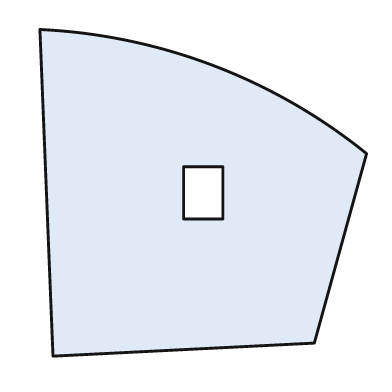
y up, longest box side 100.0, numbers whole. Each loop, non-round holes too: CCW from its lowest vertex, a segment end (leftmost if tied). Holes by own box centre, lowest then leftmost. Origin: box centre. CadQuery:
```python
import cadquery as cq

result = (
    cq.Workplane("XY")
    .moveTo(-46.0, -50.0)
    .lineTo(34.0, -46.0)
    .lineTo(50.0, 12.0)
    .threePointArc((3.0, 39.0), (-50.0, 50.0))
    .close()
    .moveTo(-6.0, -8.0)
    .lineTo(6.0, -8.0)
    .lineTo(6.0, 8.0)
    .lineTo(-6.0, 8.0)
    .close()
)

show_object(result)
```